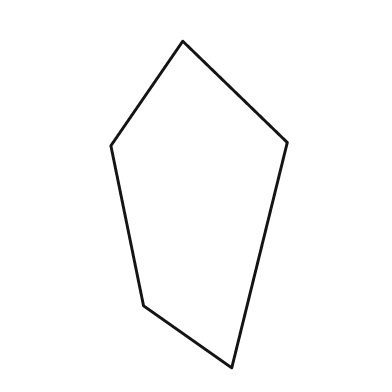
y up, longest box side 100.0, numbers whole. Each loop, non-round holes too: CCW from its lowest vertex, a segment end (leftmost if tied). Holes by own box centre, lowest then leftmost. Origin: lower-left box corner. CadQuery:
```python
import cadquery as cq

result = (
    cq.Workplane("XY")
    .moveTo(37.0, 0.0)
    .lineTo(54.0, 69.0)
    .lineTo(22.0, 100.0)
    .lineTo(0.0, 68.0)
    .lineTo(10.0, 19.0)
    .close()
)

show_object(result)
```